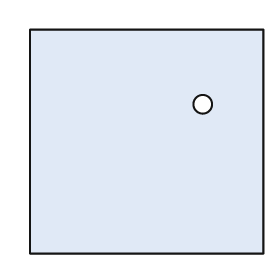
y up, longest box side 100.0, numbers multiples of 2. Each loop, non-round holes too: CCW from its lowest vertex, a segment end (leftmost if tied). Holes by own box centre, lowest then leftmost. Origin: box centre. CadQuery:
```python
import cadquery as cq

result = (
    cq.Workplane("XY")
    .moveTo(-50.0, -48.0)
    .lineTo(50.0, -48.0)
    .lineTo(50.0, 48.0)
    .lineTo(-50.0, 48.0)
    .close()
    .moveTo(24.0, 16.0)
    .circle(4.0)
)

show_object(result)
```